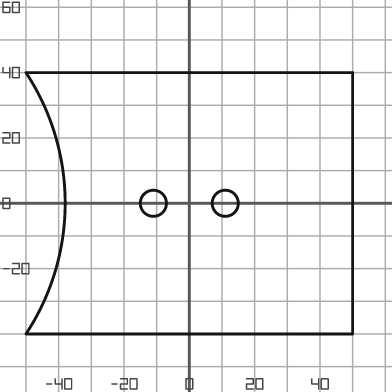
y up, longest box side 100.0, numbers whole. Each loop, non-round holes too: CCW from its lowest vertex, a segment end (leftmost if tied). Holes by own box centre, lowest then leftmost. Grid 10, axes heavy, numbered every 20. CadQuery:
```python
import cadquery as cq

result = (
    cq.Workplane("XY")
    .moveTo(-50.0, -40.0)
    .lineTo(50.0, -40.0)
    .lineTo(50.0, 40.0)
    .lineTo(-50.0, 40.0)
    .threePointArc((-38.0, 0.0), (-50.0, -40.0))
    .close()
    .moveTo(-11.0, 0.0)
    .circle(4.0)
    .moveTo(11.0, 0.0)
    .circle(4.0)
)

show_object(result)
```